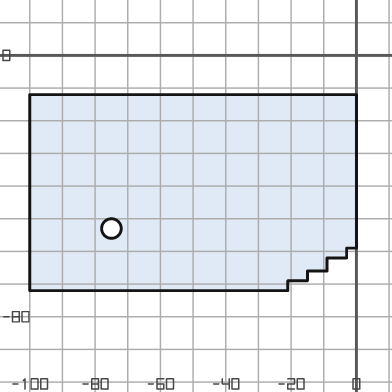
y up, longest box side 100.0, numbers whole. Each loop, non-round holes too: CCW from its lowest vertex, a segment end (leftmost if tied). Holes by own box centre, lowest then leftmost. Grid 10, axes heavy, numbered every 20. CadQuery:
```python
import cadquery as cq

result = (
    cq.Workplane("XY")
    .moveTo(-100.0, -72.0)
    .lineTo(-21.0, -72.0)
    .lineTo(-21.0, -69.0)
    .lineTo(-15.0, -69.0)
    .lineTo(-15.0, -66.0)
    .lineTo(-9.0, -66.0)
    .lineTo(-9.0, -62.0)
    .lineTo(-3.0, -62.0)
    .lineTo(-3.0, -59.0)
    .lineTo(0.0, -59.0)
    .lineTo(0.0, -12.0)
    .lineTo(-100.0, -12.0)
    .close()
    .moveTo(-75.0, -53.0)
    .circle(3.0)
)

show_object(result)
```